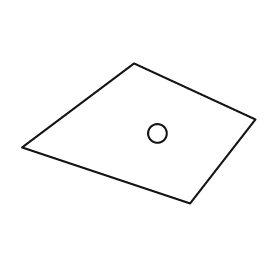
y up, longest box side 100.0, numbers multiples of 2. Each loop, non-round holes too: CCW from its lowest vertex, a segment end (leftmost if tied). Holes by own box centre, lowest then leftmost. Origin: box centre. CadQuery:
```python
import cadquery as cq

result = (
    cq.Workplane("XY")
    .moveTo(22.0, -30.0)
    .lineTo(50.0, 6.0)
    .lineTo(-2.0, 30.0)
    .lineTo(-50.0, -6.0)
    .close()
    .moveTo(8.0, 0.0)
    .circle(4.0)
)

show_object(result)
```